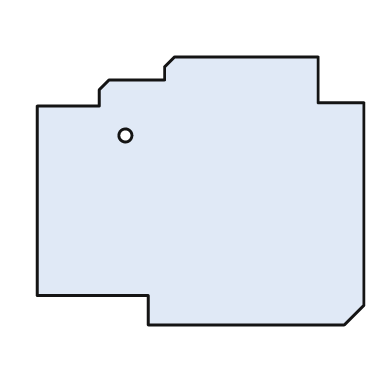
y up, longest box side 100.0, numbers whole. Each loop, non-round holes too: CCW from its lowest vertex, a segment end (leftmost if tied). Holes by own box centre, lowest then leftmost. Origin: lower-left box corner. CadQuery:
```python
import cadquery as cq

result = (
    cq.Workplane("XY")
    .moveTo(34.0, 0.0)
    .lineTo(94.0, 0.0)
    .lineTo(100.0, 6.0)
    .lineTo(100.0, 68.0)
    .lineTo(86.0, 68.0)
    .lineTo(86.0, 82.0)
    .lineTo(42.0, 82.0)
    .lineTo(39.0, 79.0)
    .lineTo(39.0, 75.0)
    .lineTo(22.0, 75.0)
    .lineTo(19.0, 72.0)
    .lineTo(19.0, 67.0)
    .lineTo(0.0, 67.0)
    .lineTo(0.0, 9.0)
    .lineTo(34.0, 9.0)
    .close()
    .moveTo(27.0, 58.0)
    .circle(2.0)
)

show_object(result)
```